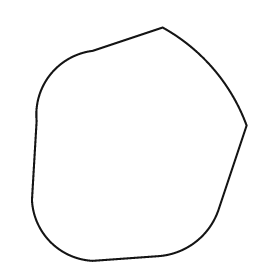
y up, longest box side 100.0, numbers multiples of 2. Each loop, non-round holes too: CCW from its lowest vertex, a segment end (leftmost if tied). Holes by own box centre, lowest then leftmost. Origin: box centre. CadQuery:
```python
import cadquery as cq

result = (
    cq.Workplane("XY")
    .moveTo(-20.0, -50.0)
    .lineTo(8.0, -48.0)
    .threePointArc((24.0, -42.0), (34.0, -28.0))
    .lineTo(46.0, 8.0)
    .threePointArc((32.0, 32.0), (10.0, 50.0))
    .lineTo(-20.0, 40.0)
    .threePointArc((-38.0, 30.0), (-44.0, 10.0))
    .lineTo(-46.0, -24.0)
    .threePointArc((-38.0, -42.0), (-20.0, -50.0))
    .close()
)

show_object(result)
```